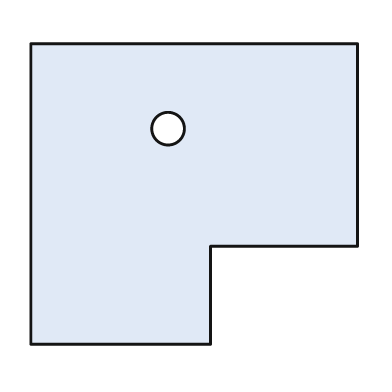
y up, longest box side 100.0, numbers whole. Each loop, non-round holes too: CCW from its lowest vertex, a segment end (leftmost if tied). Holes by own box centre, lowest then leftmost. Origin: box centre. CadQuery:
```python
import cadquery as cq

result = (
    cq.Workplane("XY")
    .moveTo(-50.0, -46.0)
    .lineTo(5.0, -46.0)
    .lineTo(5.0, -16.0)
    .lineTo(50.0, -16.0)
    .lineTo(50.0, 46.0)
    .lineTo(-50.0, 46.0)
    .close()
    .moveTo(-8.0, 20.0)
    .circle(5.0)
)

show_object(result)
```